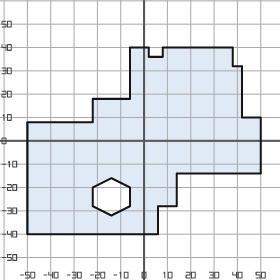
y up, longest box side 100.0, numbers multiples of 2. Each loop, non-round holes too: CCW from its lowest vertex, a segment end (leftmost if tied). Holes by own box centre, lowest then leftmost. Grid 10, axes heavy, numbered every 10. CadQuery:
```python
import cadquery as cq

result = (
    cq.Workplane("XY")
    .moveTo(-50.0, -40.0)
    .lineTo(6.0, -40.0)
    .lineTo(6.0, -28.0)
    .lineTo(14.0, -28.0)
    .lineTo(14.0, -14.0)
    .lineTo(50.0, -14.0)
    .lineTo(50.0, 10.0)
    .lineTo(42.0, 10.0)
    .lineTo(42.0, 32.0)
    .lineTo(38.0, 32.0)
    .lineTo(38.0, 40.0)
    .lineTo(8.0, 40.0)
    .lineTo(8.0, 36.0)
    .lineTo(2.0, 36.0)
    .lineTo(2.0, 40.0)
    .lineTo(-6.0, 40.0)
    .lineTo(-6.0, 18.0)
    .lineTo(-22.0, 18.0)
    .lineTo(-22.0, 8.0)
    .lineTo(-50.0, 8.0)
    .close()
    .moveTo(-14.0, -32.0)
    .lineTo(-6.0, -28.0)
    .lineTo(-6.0, -20.0)
    .lineTo(-14.0, -16.0)
    .lineTo(-22.0, -20.0)
    .lineTo(-22.0, -28.0)
    .close()
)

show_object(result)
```